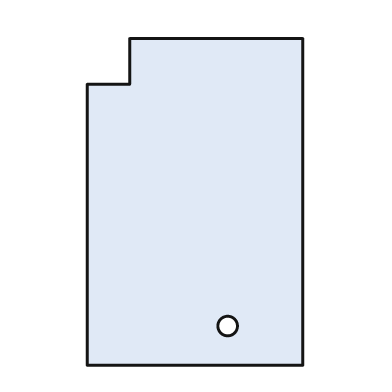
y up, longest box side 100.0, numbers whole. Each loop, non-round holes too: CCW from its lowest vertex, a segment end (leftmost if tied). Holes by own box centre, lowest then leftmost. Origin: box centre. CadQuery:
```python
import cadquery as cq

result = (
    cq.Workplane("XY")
    .moveTo(-33.0, -50.0)
    .lineTo(33.0, -50.0)
    .lineTo(33.0, 50.0)
    .lineTo(-20.0, 50.0)
    .lineTo(-20.0, 36.0)
    .lineTo(-33.0, 36.0)
    .close()
    .moveTo(10.0, -38.0)
    .circle(3.0)
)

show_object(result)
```